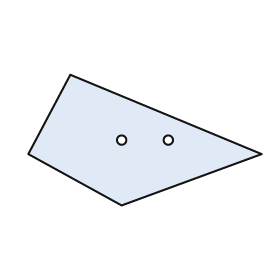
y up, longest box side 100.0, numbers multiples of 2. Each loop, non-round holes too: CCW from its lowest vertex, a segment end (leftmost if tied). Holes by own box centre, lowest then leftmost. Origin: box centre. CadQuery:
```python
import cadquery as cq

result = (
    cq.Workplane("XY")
    .moveTo(-10.0, -28.0)
    .lineTo(50.0, -6.0)
    .lineTo(-32.0, 28.0)
    .lineTo(-50.0, -6.0)
    .close()
    .moveTo(-10.0, 0.0)
    .circle(2.0)
    .moveTo(10.0, 0.0)
    .circle(2.0)
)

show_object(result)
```